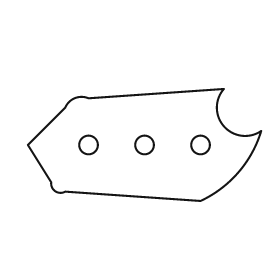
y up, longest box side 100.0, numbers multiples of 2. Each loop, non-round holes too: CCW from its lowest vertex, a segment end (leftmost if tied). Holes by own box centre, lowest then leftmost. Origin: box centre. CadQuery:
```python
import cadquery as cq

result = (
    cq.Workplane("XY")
    .moveTo(24.0, -24.0)
    .threePointArc((40.0, -12.0), (50.0, 6.0))
    .threePointArc((34.0, 8.0), (34.0, 24.0))
    .lineTo(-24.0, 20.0)
    .threePointArc((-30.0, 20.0), (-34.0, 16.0))
    .lineTo(-50.0, 0.0)
    .lineTo(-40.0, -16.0)
    .threePointArc((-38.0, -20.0), (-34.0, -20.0))
    .close()
    .moveTo(-24.0, 0.0)
    .circle(4.0)
    .moveTo(0.0, 0.0)
    .circle(4.0)
    .moveTo(24.0, 0.0)
    .circle(4.0)
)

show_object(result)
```